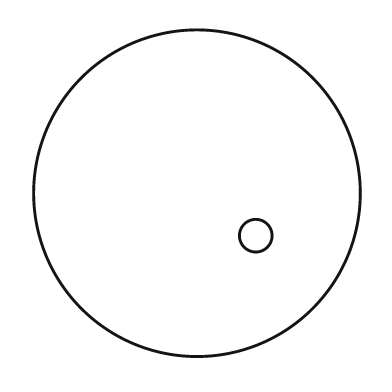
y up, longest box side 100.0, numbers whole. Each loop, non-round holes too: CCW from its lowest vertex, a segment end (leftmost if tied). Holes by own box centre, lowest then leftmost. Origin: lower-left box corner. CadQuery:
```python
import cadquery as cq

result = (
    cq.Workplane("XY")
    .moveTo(50.0, 50.0)
    .circle(50.0)
    .moveTo(68.0, 37.0)
    .circle(5.0)
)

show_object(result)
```